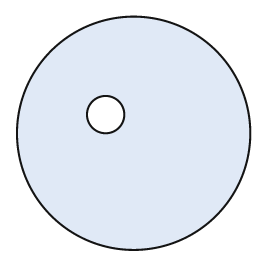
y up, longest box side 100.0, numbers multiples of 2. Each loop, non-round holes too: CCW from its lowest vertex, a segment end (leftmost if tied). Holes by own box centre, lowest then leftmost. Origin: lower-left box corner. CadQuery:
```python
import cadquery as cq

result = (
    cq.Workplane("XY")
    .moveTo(50.0, 50.0)
    .circle(50.0)
    .moveTo(38.0, 58.0)
    .circle(8.0)
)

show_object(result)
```